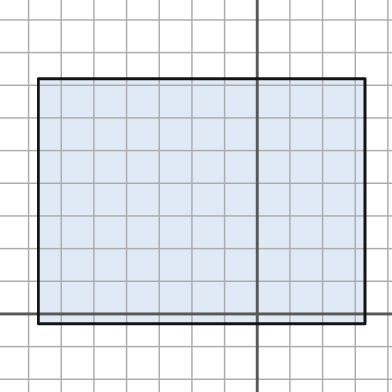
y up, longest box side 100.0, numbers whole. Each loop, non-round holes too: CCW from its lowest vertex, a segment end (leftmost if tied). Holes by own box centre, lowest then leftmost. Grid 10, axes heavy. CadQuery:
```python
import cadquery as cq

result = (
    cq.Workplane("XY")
    .moveTo(-67.0, -3.0)
    .lineTo(33.0, -3.0)
    .lineTo(33.0, 72.0)
    .lineTo(-67.0, 72.0)
    .close()
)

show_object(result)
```